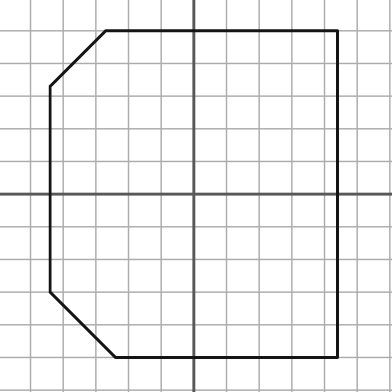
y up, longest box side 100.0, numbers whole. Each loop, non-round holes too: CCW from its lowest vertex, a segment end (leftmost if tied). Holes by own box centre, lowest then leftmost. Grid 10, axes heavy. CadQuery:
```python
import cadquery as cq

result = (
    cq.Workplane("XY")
    .moveTo(-24.0, -50.0)
    .lineTo(44.0, -50.0)
    .lineTo(44.0, 50.0)
    .lineTo(-27.0, 50.0)
    .lineTo(-44.0, 33.0)
    .lineTo(-44.0, -30.0)
    .close()
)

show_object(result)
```